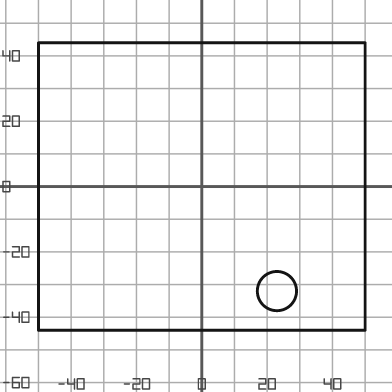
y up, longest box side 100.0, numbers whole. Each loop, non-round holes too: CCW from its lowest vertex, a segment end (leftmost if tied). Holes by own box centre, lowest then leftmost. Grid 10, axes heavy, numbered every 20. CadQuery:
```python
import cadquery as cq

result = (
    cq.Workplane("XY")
    .moveTo(-50.0, -44.0)
    .lineTo(50.0, -44.0)
    .lineTo(50.0, 44.0)
    .lineTo(-50.0, 44.0)
    .close()
    .moveTo(23.0, -32.0)
    .circle(6.0)
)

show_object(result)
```